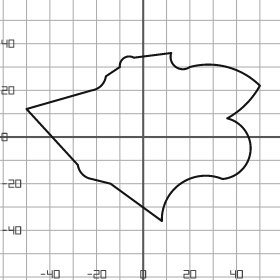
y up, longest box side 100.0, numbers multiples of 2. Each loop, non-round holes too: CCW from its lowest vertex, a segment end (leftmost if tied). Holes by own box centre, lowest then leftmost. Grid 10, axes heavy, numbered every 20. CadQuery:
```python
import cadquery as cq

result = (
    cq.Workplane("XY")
    .moveTo(8.0, -36.0)
    .threePointArc((16.0, -20.0), (34.0, -18.0))
    .threePointArc((46.0, -6.0), (36.0, 8.0))
    .threePointArc((44.0, 14.0), (50.0, 22.0))
    .threePointArc((36.0, 30.0), (20.0, 30.0))
    .threePointArc((14.0, 30.0), (12.0, 36.0))
    .lineTo(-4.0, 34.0)
    .threePointArc((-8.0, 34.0), (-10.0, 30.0))
    .lineTo(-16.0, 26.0)
    .threePointArc((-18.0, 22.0), (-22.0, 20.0))
    .lineTo(-50.0, 12.0)
    .lineTo(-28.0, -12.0)
    .threePointArc((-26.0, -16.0), (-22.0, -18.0))
    .lineTo(-14.0, -20.0)
    .close()
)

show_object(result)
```